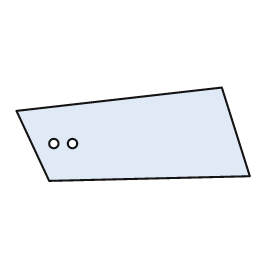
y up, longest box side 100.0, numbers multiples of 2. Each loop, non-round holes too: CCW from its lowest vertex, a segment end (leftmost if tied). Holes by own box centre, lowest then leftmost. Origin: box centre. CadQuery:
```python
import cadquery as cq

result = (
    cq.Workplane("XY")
    .moveTo(-36.0, -20.0)
    .lineTo(50.0, -18.0)
    .lineTo(38.0, 20.0)
    .lineTo(-50.0, 10.0)
    .close()
    .moveTo(-34.0, -4.0)
    .circle(2.0)
    .moveTo(-26.0, -4.0)
    .circle(2.0)
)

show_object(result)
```